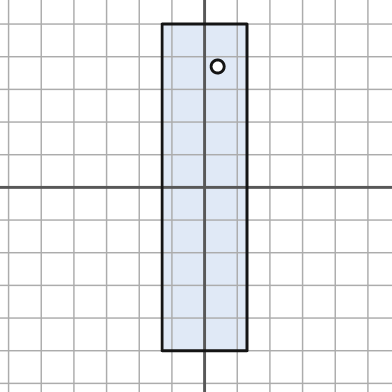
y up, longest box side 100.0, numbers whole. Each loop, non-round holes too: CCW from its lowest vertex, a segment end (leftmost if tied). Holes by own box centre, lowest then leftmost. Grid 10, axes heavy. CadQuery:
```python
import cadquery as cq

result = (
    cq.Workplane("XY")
    .moveTo(-13.0, -50.0)
    .lineTo(13.0, -50.0)
    .lineTo(13.0, 50.0)
    .lineTo(-13.0, 50.0)
    .close()
    .moveTo(4.0, 37.0)
    .circle(2.0)
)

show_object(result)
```